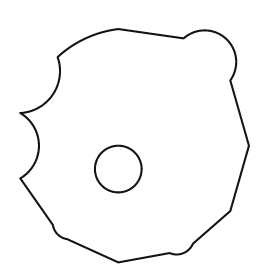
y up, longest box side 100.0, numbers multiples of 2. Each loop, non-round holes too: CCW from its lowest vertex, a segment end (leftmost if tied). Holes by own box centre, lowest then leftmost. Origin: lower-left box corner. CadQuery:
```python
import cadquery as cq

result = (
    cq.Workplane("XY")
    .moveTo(42.0, 0.0)
    .lineTo(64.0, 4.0)
    .threePointArc((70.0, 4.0), (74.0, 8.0))
    .lineTo(90.0, 22.0)
    .lineTo(98.0, 50.0)
    .lineTo(90.0, 78.0)
    .threePointArc((88.0, 96.0), (70.0, 96.0))
    .lineTo(42.0, 100.0)
    .threePointArc((28.0, 96.0), (16.0, 88.0))
    .threePointArc((14.0, 72.0), (0.0, 64.0))
    .threePointArc((8.0, 50.0), (0.0, 36.0))
    .lineTo(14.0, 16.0)
    .threePointArc((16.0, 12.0), (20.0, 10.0))
    .close()
    .moveTo(42.0, 40.0)
    .circle(10.0)
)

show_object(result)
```